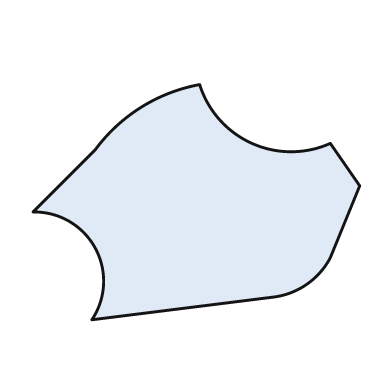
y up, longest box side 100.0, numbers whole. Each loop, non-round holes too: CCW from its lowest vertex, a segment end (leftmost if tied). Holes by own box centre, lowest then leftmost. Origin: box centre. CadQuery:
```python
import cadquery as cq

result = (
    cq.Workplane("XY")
    .moveTo(-32.0, -36.0)
    .lineTo(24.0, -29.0)
    .threePointArc((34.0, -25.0), (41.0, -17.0))
    .lineTo(50.0, 5.0)
    .lineTo(41.0, 18.0)
    .threePointArc((17.0, 18.0), (1.0, 36.0))
    .threePointArc((-17.0, 29.0), (-31.0, 16.0))
    .lineTo(-50.0, -3.0)
    .threePointArc((-31.0, -14.0), (-32.0, -36.0))
    .close()
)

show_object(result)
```